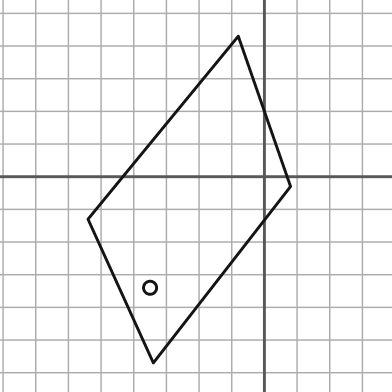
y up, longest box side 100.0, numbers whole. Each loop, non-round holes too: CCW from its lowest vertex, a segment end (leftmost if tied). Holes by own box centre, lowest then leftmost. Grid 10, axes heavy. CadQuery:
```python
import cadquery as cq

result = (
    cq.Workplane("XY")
    .moveTo(-34.0, -57.0)
    .lineTo(8.0, -3.0)
    .lineTo(-8.0, 43.0)
    .lineTo(-54.0, -13.0)
    .close()
    .moveTo(-35.0, -34.0)
    .circle(2.0)
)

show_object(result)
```